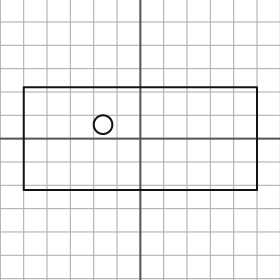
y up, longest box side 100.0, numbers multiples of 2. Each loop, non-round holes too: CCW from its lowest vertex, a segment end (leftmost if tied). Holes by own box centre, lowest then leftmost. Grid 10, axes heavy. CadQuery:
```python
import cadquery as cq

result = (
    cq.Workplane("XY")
    .moveTo(-50.0, -22.0)
    .lineTo(50.0, -22.0)
    .lineTo(50.0, 22.0)
    .lineTo(-50.0, 22.0)
    .close()
    .moveTo(-16.0, 6.0)
    .circle(4.0)
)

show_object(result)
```